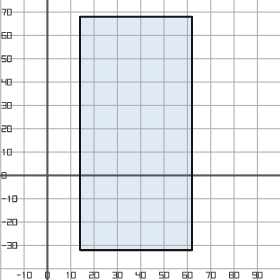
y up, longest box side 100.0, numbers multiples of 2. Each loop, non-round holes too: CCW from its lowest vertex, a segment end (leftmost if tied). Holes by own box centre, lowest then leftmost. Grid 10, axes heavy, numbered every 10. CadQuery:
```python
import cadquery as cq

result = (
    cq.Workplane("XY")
    .moveTo(14.0, -32.0)
    .lineTo(62.0, -32.0)
    .lineTo(62.0, 68.0)
    .lineTo(14.0, 68.0)
    .close()
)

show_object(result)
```